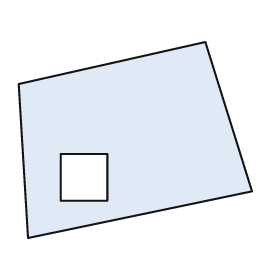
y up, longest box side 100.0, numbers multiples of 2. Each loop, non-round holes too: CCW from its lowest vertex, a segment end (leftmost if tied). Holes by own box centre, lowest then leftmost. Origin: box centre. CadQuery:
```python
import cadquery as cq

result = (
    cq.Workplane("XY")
    .moveTo(-46.0, -42.0)
    .lineTo(50.0, -22.0)
    .lineTo(30.0, 42.0)
    .lineTo(-50.0, 24.0)
    .close()
    .moveTo(-32.0, -26.0)
    .lineTo(-12.0, -26.0)
    .lineTo(-12.0, -6.0)
    .lineTo(-32.0, -6.0)
    .close()
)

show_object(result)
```